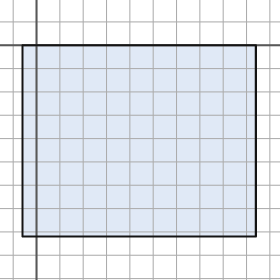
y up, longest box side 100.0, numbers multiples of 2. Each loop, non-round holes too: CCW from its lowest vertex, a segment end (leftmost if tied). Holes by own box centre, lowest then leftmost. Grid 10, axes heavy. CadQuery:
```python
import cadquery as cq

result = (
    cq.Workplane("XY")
    .moveTo(-6.0, -82.0)
    .lineTo(94.0, -82.0)
    .lineTo(94.0, 0.0)
    .lineTo(-6.0, 0.0)
    .close()
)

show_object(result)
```